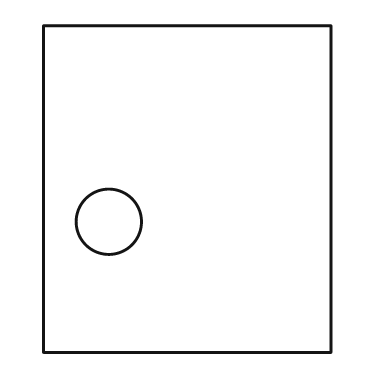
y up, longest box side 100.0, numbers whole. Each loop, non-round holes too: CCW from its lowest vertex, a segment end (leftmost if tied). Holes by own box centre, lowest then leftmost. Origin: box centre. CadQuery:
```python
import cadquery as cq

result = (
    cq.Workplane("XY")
    .moveTo(-44.0, -50.0)
    .lineTo(44.0, -50.0)
    .lineTo(44.0, 50.0)
    .lineTo(-44.0, 50.0)
    .close()
    .moveTo(-24.0, -10.0)
    .circle(10.0)
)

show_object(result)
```